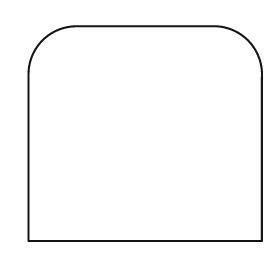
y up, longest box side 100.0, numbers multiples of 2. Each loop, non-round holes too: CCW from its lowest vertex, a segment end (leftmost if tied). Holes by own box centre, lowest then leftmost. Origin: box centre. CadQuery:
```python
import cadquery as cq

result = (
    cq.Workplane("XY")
    .moveTo(-50.0, -46.0)
    .lineTo(50.0, -46.0)
    .lineTo(50.0, 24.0)
    .threePointArc((44.0, 40.0), (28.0, 46.0))
    .lineTo(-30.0, 46.0)
    .threePointArc((-44.0, 40.0), (-50.0, 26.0))
    .close()
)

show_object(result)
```